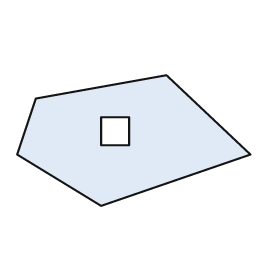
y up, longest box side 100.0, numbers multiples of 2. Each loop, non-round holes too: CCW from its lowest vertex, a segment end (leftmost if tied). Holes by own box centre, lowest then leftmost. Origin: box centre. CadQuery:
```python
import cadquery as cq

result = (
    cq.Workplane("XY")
    .moveTo(-14.0, -28.0)
    .lineTo(50.0, -6.0)
    .lineTo(14.0, 28.0)
    .lineTo(-42.0, 18.0)
    .lineTo(-50.0, -6.0)
    .close()
    .moveTo(-14.0, -2.0)
    .lineTo(-2.0, -2.0)
    .lineTo(-2.0, 10.0)
    .lineTo(-14.0, 10.0)
    .close()
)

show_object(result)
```